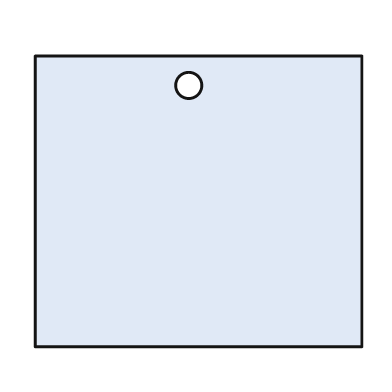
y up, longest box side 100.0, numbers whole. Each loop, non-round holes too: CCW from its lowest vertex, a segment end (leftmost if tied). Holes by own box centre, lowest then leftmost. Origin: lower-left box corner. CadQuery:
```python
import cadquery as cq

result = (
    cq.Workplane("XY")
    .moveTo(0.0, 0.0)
    .lineTo(100.0, 0.0)
    .lineTo(100.0, 89.0)
    .lineTo(0.0, 89.0)
    .close()
    .moveTo(47.0, 80.0)
    .circle(4.0)
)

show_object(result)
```